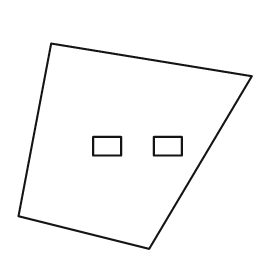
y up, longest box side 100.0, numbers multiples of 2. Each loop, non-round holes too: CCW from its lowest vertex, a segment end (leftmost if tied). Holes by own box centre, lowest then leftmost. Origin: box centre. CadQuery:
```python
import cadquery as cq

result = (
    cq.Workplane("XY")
    .moveTo(6.0, -44.0)
    .lineTo(50.0, 30.0)
    .lineTo(-36.0, 44.0)
    .lineTo(-50.0, -30.0)
    .close()
    .moveTo(-18.0, -4.0)
    .lineTo(-6.0, -4.0)
    .lineTo(-6.0, 4.0)
    .lineTo(-18.0, 4.0)
    .close()
    .moveTo(8.0, -4.0)
    .lineTo(20.0, -4.0)
    .lineTo(20.0, 4.0)
    .lineTo(8.0, 4.0)
    .close()
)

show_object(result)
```